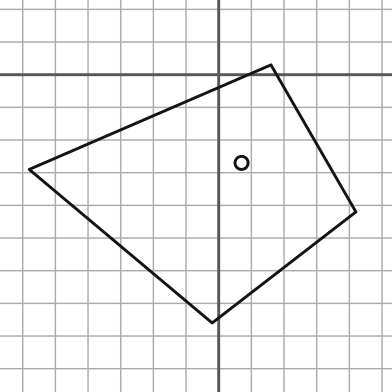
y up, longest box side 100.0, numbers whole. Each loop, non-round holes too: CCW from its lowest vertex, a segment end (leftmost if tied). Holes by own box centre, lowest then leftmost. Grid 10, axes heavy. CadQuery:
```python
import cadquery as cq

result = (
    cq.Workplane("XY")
    .moveTo(-2.0, -76.0)
    .lineTo(42.0, -42.0)
    .lineTo(16.0, 3.0)
    .lineTo(-58.0, -29.0)
    .close()
    .moveTo(7.0, -27.0)
    .circle(2.0)
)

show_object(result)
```